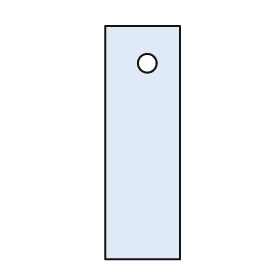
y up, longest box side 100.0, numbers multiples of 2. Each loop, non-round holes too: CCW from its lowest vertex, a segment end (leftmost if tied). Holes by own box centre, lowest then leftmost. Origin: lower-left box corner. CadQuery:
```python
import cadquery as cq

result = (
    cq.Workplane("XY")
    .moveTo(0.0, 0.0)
    .lineTo(32.0, 0.0)
    .lineTo(32.0, 100.0)
    .lineTo(0.0, 100.0)
    .close()
    .moveTo(18.0, 84.0)
    .circle(4.0)
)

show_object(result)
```